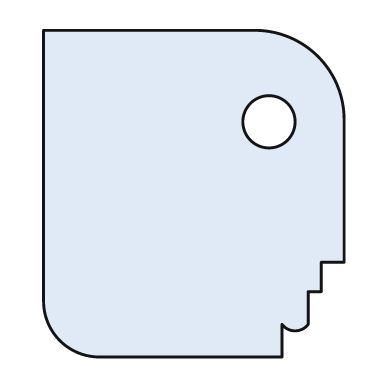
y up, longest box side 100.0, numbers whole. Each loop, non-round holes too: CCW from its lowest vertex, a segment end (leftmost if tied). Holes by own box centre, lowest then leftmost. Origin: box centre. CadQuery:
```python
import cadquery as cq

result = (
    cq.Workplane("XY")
    .moveTo(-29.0, -50.0)
    .lineTo(27.0, -50.0)
    .lineTo(27.0, -40.0)
    .threePointArc((31.0, -42.0), (35.0, -40.0))
    .lineTo(35.0, -30.0)
    .lineTo(39.0, -30.0)
    .lineTo(39.0, -21.0)
    .lineTo(46.0, -21.0)
    .lineTo(46.0, 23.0)
    .threePointArc((38.0, 42.0), (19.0, 50.0))
    .lineTo(-46.0, 50.0)
    .lineTo(-46.0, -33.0)
    .threePointArc((-41.0, -45.0), (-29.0, -50.0))
    .close()
    .moveTo(23.0, 22.0)
    .circle(8.0)
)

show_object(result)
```